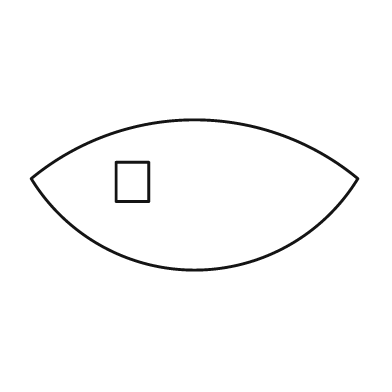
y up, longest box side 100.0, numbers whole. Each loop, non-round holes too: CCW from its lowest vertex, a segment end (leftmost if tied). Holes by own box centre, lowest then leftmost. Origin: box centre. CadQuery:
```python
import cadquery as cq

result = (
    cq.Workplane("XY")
    .moveTo(-50.0, 5.0)
    .threePointArc((0.0, -23.0), (50.0, 5.0))
    .threePointArc((0.0, 23.0), (-50.0, 5.0))
    .close()
    .moveTo(-24.0, -2.0)
    .lineTo(-14.0, -2.0)
    .lineTo(-14.0, 10.0)
    .lineTo(-24.0, 10.0)
    .close()
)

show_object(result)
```